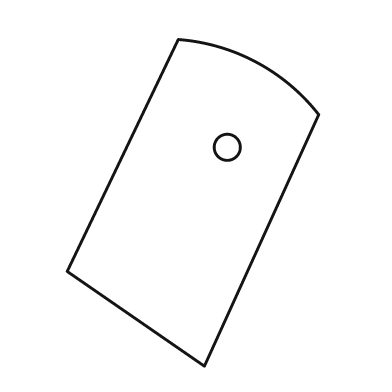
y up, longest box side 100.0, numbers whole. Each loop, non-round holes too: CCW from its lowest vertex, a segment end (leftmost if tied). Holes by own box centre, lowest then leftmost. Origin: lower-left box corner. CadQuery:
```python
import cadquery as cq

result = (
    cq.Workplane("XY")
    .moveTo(42.0, 0.0)
    .lineTo(77.0, 77.0)
    .threePointArc((58.0, 93.0), (34.0, 100.0))
    .lineTo(0.0, 29.0)
    .close()
    .moveTo(49.0, 67.0)
    .circle(4.0)
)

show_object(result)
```